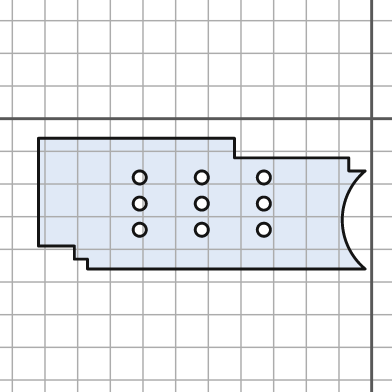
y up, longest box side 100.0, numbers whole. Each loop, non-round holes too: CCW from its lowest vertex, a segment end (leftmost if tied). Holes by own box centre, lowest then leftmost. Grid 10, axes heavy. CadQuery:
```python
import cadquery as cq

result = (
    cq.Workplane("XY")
    .moveTo(-87.0, -46.0)
    .lineTo(-2.0, -46.0)
    .threePointArc((-9.0, -31.0), (-2.0, -16.0))
    .lineTo(-7.0, -16.0)
    .lineTo(-7.0, -12.0)
    .lineTo(-42.0, -12.0)
    .lineTo(-42.0, -6.0)
    .lineTo(-102.0, -6.0)
    .lineTo(-102.0, -39.0)
    .lineTo(-91.0, -39.0)
    .lineTo(-91.0, -43.0)
    .lineTo(-87.0, -43.0)
    .close()
    .moveTo(-71.0, -34.0)
    .circle(2.0)
    .moveTo(-52.0, -34.0)
    .circle(2.0)
    .moveTo(-33.0, -34.0)
    .circle(2.0)
    .moveTo(-71.0, -26.0)
    .circle(2.0)
    .moveTo(-52.0, -26.0)
    .circle(2.0)
    .moveTo(-33.0, -26.0)
    .circle(2.0)
    .moveTo(-71.0, -18.0)
    .circle(2.0)
    .moveTo(-52.0, -18.0)
    .circle(2.0)
    .moveTo(-33.0, -18.0)
    .circle(2.0)
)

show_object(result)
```